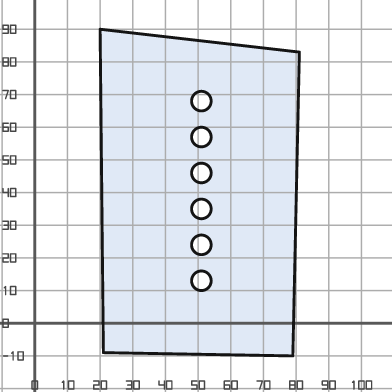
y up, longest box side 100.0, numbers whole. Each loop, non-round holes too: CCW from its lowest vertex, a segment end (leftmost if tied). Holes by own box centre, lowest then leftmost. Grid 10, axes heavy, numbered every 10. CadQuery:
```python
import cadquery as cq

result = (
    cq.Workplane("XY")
    .moveTo(79.0, -10.0)
    .lineTo(81.0, 83.0)
    .lineTo(20.0, 90.0)
    .lineTo(21.0, -9.0)
    .close()
    .moveTo(51.0, 13.0)
    .circle(3.0)
    .moveTo(51.0, 24.0)
    .circle(3.0)
    .moveTo(51.0, 35.0)
    .circle(3.0)
    .moveTo(51.0, 46.0)
    .circle(3.0)
    .moveTo(51.0, 57.0)
    .circle(3.0)
    .moveTo(51.0, 68.0)
    .circle(3.0)
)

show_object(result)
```